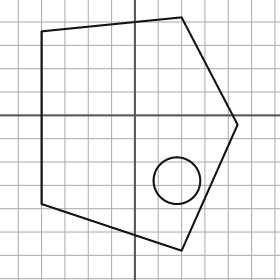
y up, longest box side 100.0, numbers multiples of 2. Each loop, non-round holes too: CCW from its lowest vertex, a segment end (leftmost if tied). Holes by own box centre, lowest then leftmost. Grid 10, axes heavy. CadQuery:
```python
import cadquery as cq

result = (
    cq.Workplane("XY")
    .moveTo(20.0, -58.0)
    .lineTo(44.0, -4.0)
    .lineTo(20.0, 42.0)
    .lineTo(-40.0, 36.0)
    .lineTo(-40.0, -38.0)
    .close()
    .moveTo(18.0, -28.0)
    .circle(10.0)
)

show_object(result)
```